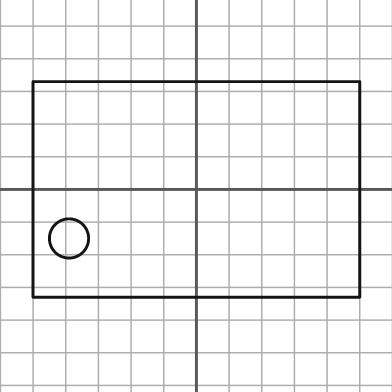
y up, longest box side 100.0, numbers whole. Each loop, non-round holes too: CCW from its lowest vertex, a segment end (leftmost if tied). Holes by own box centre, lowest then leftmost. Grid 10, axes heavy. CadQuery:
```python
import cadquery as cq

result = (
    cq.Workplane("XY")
    .moveTo(-50.0, -33.0)
    .lineTo(50.0, -33.0)
    .lineTo(50.0, 33.0)
    .lineTo(-50.0, 33.0)
    .close()
    .moveTo(-39.0, -15.0)
    .circle(6.0)
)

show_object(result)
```